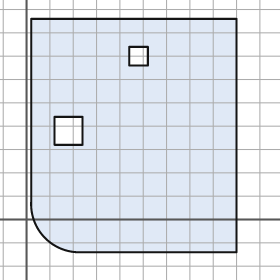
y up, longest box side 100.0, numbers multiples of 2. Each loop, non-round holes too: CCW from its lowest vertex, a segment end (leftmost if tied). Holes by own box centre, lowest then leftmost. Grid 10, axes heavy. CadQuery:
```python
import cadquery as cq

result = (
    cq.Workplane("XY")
    .moveTo(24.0, -14.0)
    .lineTo(90.0, -14.0)
    .lineTo(90.0, 86.0)
    .lineTo(2.0, 86.0)
    .lineTo(2.0, 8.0)
    .threePointArc((8.0, -8.0), (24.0, -14.0))
    .close()
    .moveTo(12.0, 32.0)
    .lineTo(24.0, 32.0)
    .lineTo(24.0, 44.0)
    .lineTo(12.0, 44.0)
    .close()
    .moveTo(44.0, 66.0)
    .lineTo(52.0, 66.0)
    .lineTo(52.0, 74.0)
    .lineTo(44.0, 74.0)
    .close()
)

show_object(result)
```